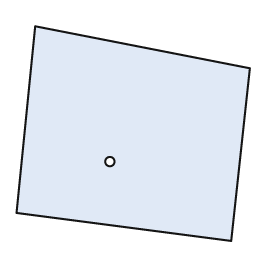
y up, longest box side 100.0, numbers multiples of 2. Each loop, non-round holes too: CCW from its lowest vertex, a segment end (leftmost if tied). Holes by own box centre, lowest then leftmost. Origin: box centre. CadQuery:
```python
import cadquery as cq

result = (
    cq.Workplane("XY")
    .moveTo(42.0, -46.0)
    .lineTo(50.0, 28.0)
    .lineTo(-42.0, 46.0)
    .lineTo(-50.0, -34.0)
    .close()
    .moveTo(-10.0, -12.0)
    .circle(2.0)
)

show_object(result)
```